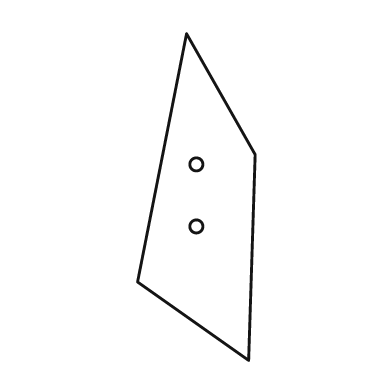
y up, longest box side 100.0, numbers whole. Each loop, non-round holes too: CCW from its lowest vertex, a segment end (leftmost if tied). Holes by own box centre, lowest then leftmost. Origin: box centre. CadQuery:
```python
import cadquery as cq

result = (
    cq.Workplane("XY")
    .moveTo(16.0, -50.0)
    .lineTo(18.0, 13.0)
    .lineTo(-3.0, 50.0)
    .lineTo(-18.0, -26.0)
    .close()
    .moveTo(0.0, -9.0)
    .circle(2.0)
    .moveTo(0.0, 10.0)
    .circle(2.0)
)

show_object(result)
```